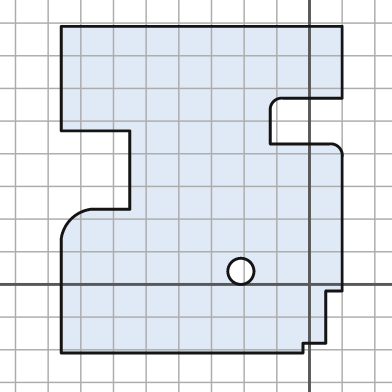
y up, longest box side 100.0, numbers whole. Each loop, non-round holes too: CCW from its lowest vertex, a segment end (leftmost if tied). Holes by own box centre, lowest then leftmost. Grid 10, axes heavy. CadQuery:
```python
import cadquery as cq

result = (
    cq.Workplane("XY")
    .moveTo(-76.0, -21.0)
    .lineTo(-2.0, -21.0)
    .lineTo(-2.0, -18.0)
    .lineTo(5.0, -18.0)
    .lineTo(5.0, -2.0)
    .lineTo(10.0, -2.0)
    .lineTo(10.0, 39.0)
    .threePointArc((9.0, 42.0), (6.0, 43.0))
    .lineTo(-12.0, 43.0)
    .lineTo(-12.0, 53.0)
    .threePointArc((-11.0, 56.0), (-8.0, 57.0))
    .lineTo(10.0, 57.0)
    .lineTo(10.0, 79.0)
    .lineTo(-76.0, 79.0)
    .lineTo(-76.0, 47.0)
    .lineTo(-55.0, 47.0)
    .lineTo(-55.0, 23.0)
    .lineTo(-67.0, 23.0)
    .threePointArc((-73.0, 20.0), (-76.0, 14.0))
    .close()
    .moveTo(-21.0, 4.0)
    .circle(4.0)
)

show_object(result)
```